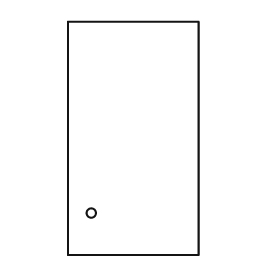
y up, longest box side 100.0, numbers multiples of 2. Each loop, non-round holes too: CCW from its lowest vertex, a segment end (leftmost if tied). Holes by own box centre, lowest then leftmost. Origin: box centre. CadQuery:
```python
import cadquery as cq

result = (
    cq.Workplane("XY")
    .moveTo(-28.0, -50.0)
    .lineTo(28.0, -50.0)
    .lineTo(28.0, 50.0)
    .lineTo(-28.0, 50.0)
    .close()
    .moveTo(-18.0, -32.0)
    .circle(2.0)
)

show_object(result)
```